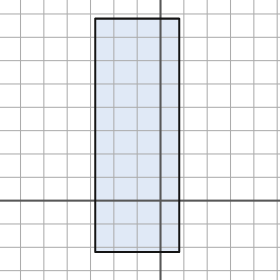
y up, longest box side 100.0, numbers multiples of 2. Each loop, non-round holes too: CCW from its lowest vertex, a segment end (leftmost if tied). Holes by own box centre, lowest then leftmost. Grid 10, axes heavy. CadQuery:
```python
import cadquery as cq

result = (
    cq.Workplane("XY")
    .moveTo(-28.0, -22.0)
    .lineTo(8.0, -22.0)
    .lineTo(8.0, 78.0)
    .lineTo(-28.0, 78.0)
    .close()
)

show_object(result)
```